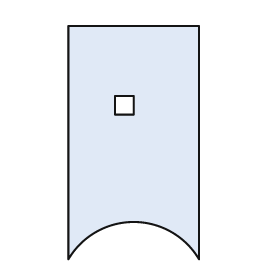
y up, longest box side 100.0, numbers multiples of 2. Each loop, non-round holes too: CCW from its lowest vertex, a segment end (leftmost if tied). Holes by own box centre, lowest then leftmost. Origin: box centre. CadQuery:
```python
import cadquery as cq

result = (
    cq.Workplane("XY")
    .moveTo(-28.0, -50.0)
    .threePointArc((0.0, -34.0), (28.0, -50.0))
    .lineTo(28.0, 50.0)
    .lineTo(-28.0, 50.0)
    .close()
    .moveTo(-8.0, 12.0)
    .lineTo(0.0, 12.0)
    .lineTo(0.0, 20.0)
    .lineTo(-8.0, 20.0)
    .close()
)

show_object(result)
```